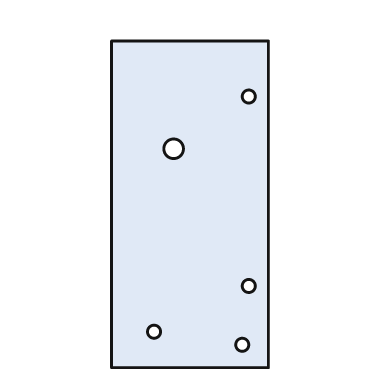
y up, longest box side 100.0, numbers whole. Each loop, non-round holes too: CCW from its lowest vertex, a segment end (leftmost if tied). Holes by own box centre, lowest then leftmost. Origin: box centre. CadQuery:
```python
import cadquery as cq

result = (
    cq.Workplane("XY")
    .moveTo(-24.0, -50.0)
    .lineTo(24.0, -50.0)
    .lineTo(24.0, 50.0)
    .lineTo(-24.0, 50.0)
    .close()
    .moveTo(16.0, -43.0)
    .circle(2.0)
    .moveTo(-11.0, -39.0)
    .circle(2.0)
    .moveTo(18.0, -25.0)
    .circle(2.0)
    .moveTo(-5.0, 17.0)
    .circle(3.0)
    .moveTo(18.0, 33.0)
    .circle(2.0)
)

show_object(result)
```